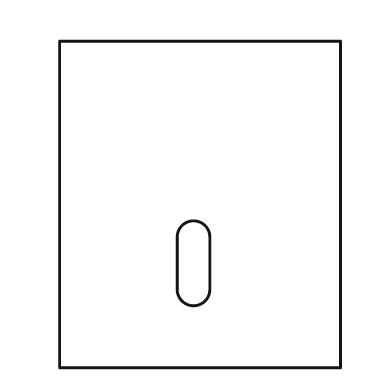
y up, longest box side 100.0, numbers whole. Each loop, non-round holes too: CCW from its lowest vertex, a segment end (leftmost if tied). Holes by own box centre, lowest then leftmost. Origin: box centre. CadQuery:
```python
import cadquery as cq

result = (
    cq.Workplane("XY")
    .moveTo(-43.0, -50.0)
    .lineTo(43.0, -50.0)
    .lineTo(43.0, 50.0)
    .lineTo(-43.0, 50.0)
    .close()
    .moveTo(-7.0, -26.0)
    .threePointArc((-2.0, -31.0), (3.0, -26.0))
    .lineTo(3.0, -10.0)
    .threePointArc((-2.0, -5.0), (-7.0, -10.0))
    .close()
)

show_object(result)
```